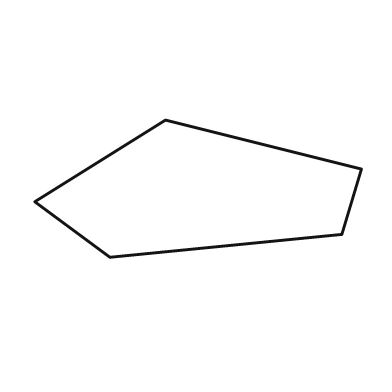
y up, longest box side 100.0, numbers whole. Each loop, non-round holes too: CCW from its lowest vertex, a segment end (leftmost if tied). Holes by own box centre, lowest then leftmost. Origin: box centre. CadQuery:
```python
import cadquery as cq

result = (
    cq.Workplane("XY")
    .moveTo(-27.0, -21.0)
    .lineTo(44.0, -14.0)
    .lineTo(50.0, 6.0)
    .lineTo(-10.0, 21.0)
    .lineTo(-50.0, -4.0)
    .close()
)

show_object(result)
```